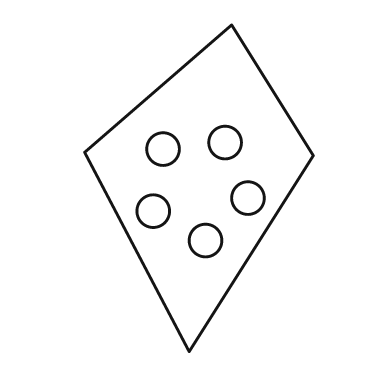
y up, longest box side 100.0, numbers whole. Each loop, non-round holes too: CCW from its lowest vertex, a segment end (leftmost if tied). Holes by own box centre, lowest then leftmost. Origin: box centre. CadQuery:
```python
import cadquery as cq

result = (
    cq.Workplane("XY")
    .moveTo(-3.0, -50.0)
    .lineTo(35.0, 10.0)
    .lineTo(10.0, 50.0)
    .lineTo(-35.0, 11.0)
    .close()
    .moveTo(2.0, -16.0)
    .circle(5.0)
    .moveTo(-14.0, -7.0)
    .circle(5.0)
    .moveTo(15.0, -3.0)
    .circle(5.0)
    .moveTo(-11.0, 12.0)
    .circle(5.0)
    .moveTo(8.0, 14.0)
    .circle(5.0)
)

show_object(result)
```